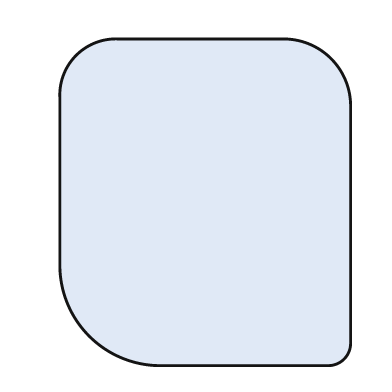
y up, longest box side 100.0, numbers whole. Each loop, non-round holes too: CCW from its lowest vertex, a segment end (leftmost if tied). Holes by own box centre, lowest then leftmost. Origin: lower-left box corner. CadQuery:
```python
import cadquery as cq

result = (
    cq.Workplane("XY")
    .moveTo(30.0, 0.0)
    .lineTo(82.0, 0.0)
    .threePointArc((87.0, 2.0), (89.0, 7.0))
    .lineTo(89.0, 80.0)
    .threePointArc((83.0, 94.0), (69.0, 100.0))
    .lineTo(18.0, 100.0)
    .threePointArc((5.0, 95.0), (0.0, 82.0))
    .lineTo(0.0, 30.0)
    .threePointArc((9.0, 9.0), (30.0, 0.0))
    .close()
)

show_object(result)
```